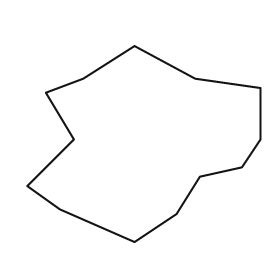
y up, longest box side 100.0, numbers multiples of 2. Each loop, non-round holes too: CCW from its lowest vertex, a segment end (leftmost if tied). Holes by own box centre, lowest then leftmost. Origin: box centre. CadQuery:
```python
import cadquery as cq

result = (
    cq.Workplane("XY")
    .moveTo(-4.0, -42.0)
    .lineTo(14.0, -30.0)
    .lineTo(24.0, -14.0)
    .lineTo(42.0, -10.0)
    .lineTo(50.0, 2.0)
    .lineTo(50.0, 24.0)
    .lineTo(22.0, 28.0)
    .lineTo(-4.0, 42.0)
    .lineTo(-26.0, 28.0)
    .lineTo(-42.0, 22.0)
    .lineTo(-30.0, 2.0)
    .lineTo(-50.0, -18.0)
    .lineTo(-36.0, -28.0)
    .close()
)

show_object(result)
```